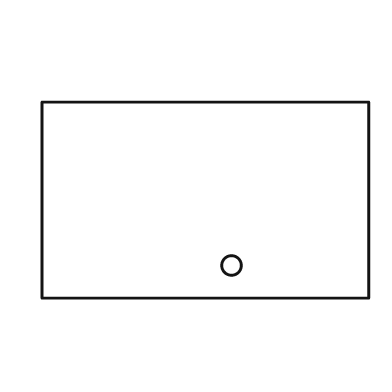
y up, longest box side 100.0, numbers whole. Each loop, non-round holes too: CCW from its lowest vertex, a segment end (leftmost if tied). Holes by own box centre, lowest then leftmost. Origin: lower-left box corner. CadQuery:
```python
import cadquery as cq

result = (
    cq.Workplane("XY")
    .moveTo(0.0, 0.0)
    .lineTo(100.0, 0.0)
    .lineTo(100.0, 60.0)
    .lineTo(0.0, 60.0)
    .close()
    .moveTo(58.0, 10.0)
    .circle(3.0)
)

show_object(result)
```